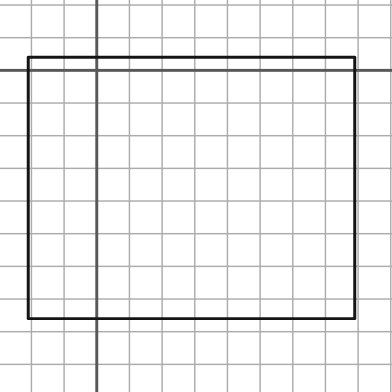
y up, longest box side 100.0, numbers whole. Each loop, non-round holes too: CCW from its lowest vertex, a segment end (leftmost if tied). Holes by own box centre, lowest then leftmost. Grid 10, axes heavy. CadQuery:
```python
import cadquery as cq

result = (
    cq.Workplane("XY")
    .moveTo(-21.0, -76.0)
    .lineTo(79.0, -76.0)
    .lineTo(79.0, 4.0)
    .lineTo(-21.0, 4.0)
    .close()
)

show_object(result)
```